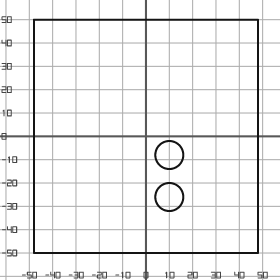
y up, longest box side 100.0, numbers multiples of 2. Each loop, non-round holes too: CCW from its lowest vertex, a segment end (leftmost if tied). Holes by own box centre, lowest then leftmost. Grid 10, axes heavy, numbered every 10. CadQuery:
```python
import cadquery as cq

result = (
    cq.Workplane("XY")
    .moveTo(-48.0, -50.0)
    .lineTo(48.0, -50.0)
    .lineTo(48.0, 50.0)
    .lineTo(-48.0, 50.0)
    .close()
    .moveTo(10.0, -26.0)
    .circle(6.0)
    .moveTo(10.0, -8.0)
    .circle(6.0)
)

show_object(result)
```